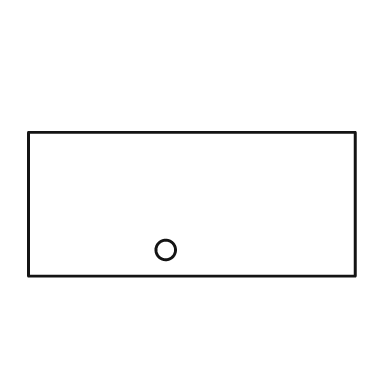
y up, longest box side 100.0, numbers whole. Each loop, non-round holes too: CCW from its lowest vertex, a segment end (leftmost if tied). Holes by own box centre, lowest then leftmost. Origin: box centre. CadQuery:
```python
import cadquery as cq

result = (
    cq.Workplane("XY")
    .moveTo(-50.0, -22.0)
    .lineTo(50.0, -22.0)
    .lineTo(50.0, 22.0)
    .lineTo(-50.0, 22.0)
    .close()
    .moveTo(-8.0, -14.0)
    .circle(3.0)
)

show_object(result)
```